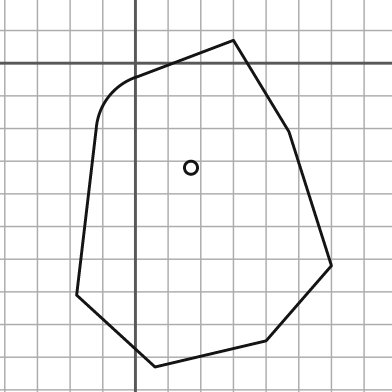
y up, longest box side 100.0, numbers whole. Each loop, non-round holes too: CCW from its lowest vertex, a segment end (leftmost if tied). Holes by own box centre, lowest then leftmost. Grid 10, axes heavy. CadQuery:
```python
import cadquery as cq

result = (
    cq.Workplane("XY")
    .moveTo(6.0, -93.0)
    .lineTo(40.0, -85.0)
    .lineTo(60.0, -62.0)
    .lineTo(47.0, -21.0)
    .lineTo(30.0, 7.0)
    .lineTo(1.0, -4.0)
    .threePointArc((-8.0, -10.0), (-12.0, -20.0))
    .lineTo(-18.0, -71.0)
    .close()
    .moveTo(17.0, -32.0)
    .circle(2.0)
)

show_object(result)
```